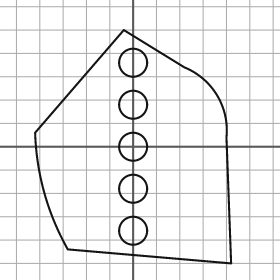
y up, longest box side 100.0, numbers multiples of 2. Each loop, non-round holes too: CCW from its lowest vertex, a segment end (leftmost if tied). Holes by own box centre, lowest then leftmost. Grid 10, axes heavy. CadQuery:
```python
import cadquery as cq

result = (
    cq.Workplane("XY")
    .moveTo(42.0, -50.0)
    .lineTo(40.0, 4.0)
    .threePointArc((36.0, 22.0), (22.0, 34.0))
    .lineTo(-4.0, 50.0)
    .lineTo(-42.0, 6.0)
    .threePointArc((-38.0, -20.0), (-28.0, -44.0))
    .close()
    .moveTo(0.0, -36.0)
    .circle(6.0)
    .moveTo(0.0, -18.0)
    .circle(6.0)
    .moveTo(0.0, 0.0)
    .circle(6.0)
    .moveTo(0.0, 18.0)
    .circle(6.0)
    .moveTo(0.0, 36.0)
    .circle(6.0)
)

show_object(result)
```